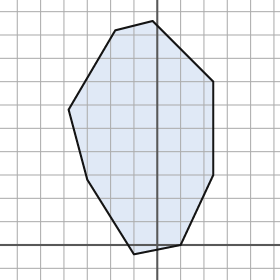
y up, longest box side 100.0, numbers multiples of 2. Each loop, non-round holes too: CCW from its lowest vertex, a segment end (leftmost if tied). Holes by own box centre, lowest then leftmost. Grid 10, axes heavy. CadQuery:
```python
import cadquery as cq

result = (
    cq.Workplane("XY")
    .moveTo(-10.0, -4.0)
    .lineTo(10.0, 0.0)
    .lineTo(24.0, 30.0)
    .lineTo(24.0, 70.0)
    .lineTo(-2.0, 96.0)
    .lineTo(-18.0, 92.0)
    .lineTo(-38.0, 58.0)
    .lineTo(-30.0, 28.0)
    .close()
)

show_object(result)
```